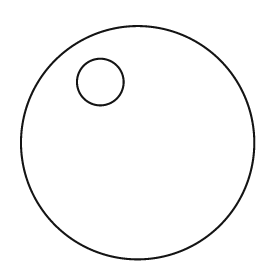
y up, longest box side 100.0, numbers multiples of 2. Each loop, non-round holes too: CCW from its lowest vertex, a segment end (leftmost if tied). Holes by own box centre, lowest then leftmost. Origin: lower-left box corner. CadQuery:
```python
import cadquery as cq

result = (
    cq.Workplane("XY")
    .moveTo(50.0, 50.0)
    .circle(50.0)
    .moveTo(34.0, 76.0)
    .circle(10.0)
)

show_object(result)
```